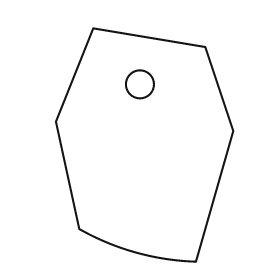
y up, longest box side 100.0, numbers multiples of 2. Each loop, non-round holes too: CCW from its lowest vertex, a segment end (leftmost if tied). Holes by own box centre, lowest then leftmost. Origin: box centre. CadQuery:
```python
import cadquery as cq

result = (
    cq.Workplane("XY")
    .moveTo(22.0, -50.0)
    .lineTo(38.0, 6.0)
    .lineTo(26.0, 42.0)
    .lineTo(-22.0, 50.0)
    .lineTo(-38.0, 10.0)
    .lineTo(-28.0, -36.0)
    .threePointArc((-4.0, -46.0), (22.0, -50.0))
    .close()
    .moveTo(-2.0, 26.0)
    .circle(6.0)
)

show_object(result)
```